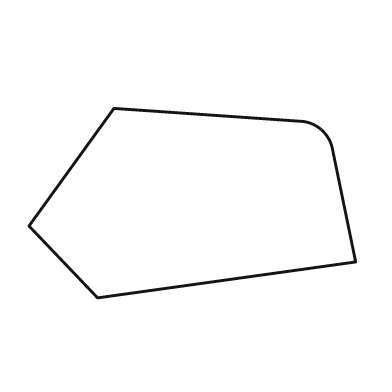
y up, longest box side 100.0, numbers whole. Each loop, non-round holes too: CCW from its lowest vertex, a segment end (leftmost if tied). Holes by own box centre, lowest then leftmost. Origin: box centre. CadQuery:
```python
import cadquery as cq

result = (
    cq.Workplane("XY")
    .moveTo(-29.0, -29.0)
    .lineTo(50.0, -18.0)
    .lineTo(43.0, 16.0)
    .threePointArc((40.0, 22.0), (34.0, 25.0))
    .lineTo(-24.0, 29.0)
    .lineTo(-50.0, -7.0)
    .close()
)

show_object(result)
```